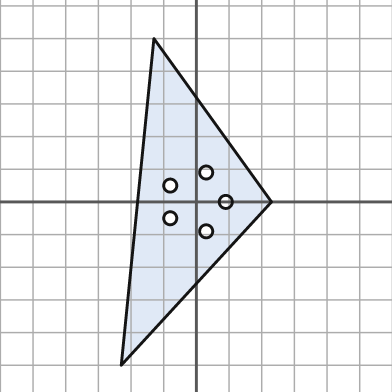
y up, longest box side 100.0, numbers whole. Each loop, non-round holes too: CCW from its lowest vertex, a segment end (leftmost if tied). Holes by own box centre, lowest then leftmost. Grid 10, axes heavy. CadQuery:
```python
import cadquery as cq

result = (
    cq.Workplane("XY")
    .moveTo(-23.0, -50.0)
    .lineTo(23.0, 0.0)
    .lineTo(-13.0, 50.0)
    .close()
    .moveTo(3.0, -9.0)
    .circle(2.0)
    .moveTo(-8.0, -5.0)
    .circle(2.0)
    .moveTo(9.0, 0.0)
    .circle(2.0)
    .moveTo(-8.0, 5.0)
    .circle(2.0)
    .moveTo(3.0, 9.0)
    .circle(2.0)
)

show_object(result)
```